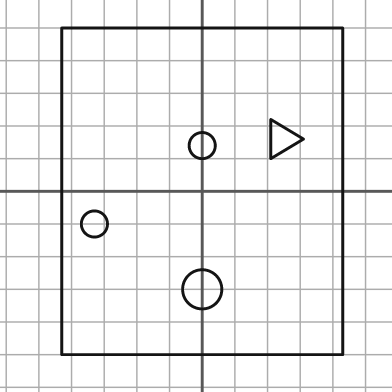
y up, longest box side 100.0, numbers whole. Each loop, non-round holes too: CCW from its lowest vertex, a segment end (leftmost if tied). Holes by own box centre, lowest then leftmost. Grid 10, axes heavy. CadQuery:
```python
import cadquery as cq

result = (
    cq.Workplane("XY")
    .moveTo(-43.0, -50.0)
    .lineTo(43.0, -50.0)
    .lineTo(43.0, 50.0)
    .lineTo(-43.0, 50.0)
    .close()
    .moveTo(0.0, -30.0)
    .circle(6.0)
    .moveTo(-33.0, -10.0)
    .circle(4.0)
    .moveTo(0.0, 14.0)
    .circle(4.0)
    .moveTo(21.0, 10.0)
    .lineTo(31.0, 16.0)
    .lineTo(21.0, 22.0)
    .close()
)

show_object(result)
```